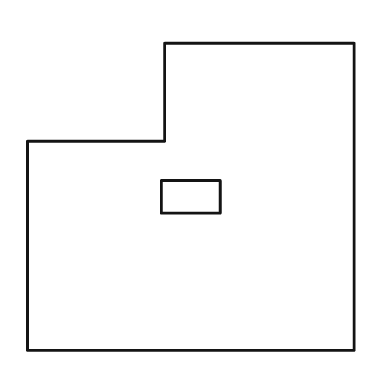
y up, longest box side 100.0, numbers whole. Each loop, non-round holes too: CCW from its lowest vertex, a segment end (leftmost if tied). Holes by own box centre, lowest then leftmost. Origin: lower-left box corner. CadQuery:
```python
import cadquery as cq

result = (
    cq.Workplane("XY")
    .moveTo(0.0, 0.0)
    .lineTo(100.0, 0.0)
    .lineTo(100.0, 94.0)
    .lineTo(42.0, 94.0)
    .lineTo(42.0, 64.0)
    .lineTo(0.0, 64.0)
    .close()
    .moveTo(41.0, 42.0)
    .lineTo(59.0, 42.0)
    .lineTo(59.0, 52.0)
    .lineTo(41.0, 52.0)
    .close()
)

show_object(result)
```